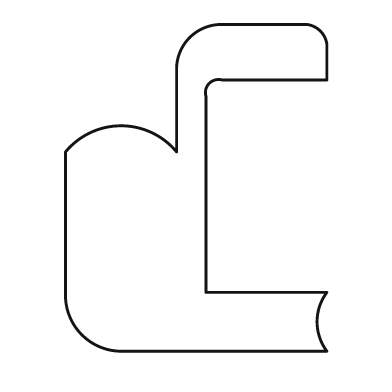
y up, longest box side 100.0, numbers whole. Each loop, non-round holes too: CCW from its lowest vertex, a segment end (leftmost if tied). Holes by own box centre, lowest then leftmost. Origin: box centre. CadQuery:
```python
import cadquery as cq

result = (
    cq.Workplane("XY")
    .moveTo(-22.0, -50.0)
    .lineTo(40.0, -50.0)
    .threePointArc((37.0, -41.0), (40.0, -32.0))
    .lineTo(3.0, -32.0)
    .lineTo(3.0, 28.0)
    .threePointArc((4.0, 32.0), (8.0, 33.0))
    .lineTo(40.0, 33.0)
    .lineTo(40.0, 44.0)
    .threePointArc((38.0, 48.0), (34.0, 50.0))
    .lineTo(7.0, 50.0)
    .threePointArc((-2.0, 46.0), (-6.0, 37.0))
    .lineTo(-6.0, 11.0)
    .threePointArc((-23.0, 19.0), (-40.0, 11.0))
    .lineTo(-40.0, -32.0)
    .threePointArc((-35.0, -45.0), (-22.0, -50.0))
    .close()
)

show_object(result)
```